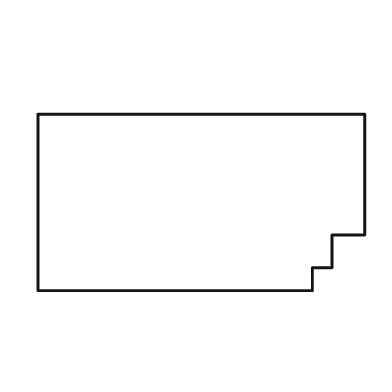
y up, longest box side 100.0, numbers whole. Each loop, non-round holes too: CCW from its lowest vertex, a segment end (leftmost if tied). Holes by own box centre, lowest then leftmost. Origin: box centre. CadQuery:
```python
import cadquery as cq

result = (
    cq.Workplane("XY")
    .moveTo(-50.0, -27.0)
    .lineTo(34.0, -27.0)
    .lineTo(34.0, -20.0)
    .lineTo(40.0, -20.0)
    .lineTo(40.0, -10.0)
    .lineTo(50.0, -10.0)
    .lineTo(50.0, 27.0)
    .lineTo(-50.0, 27.0)
    .close()
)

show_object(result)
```